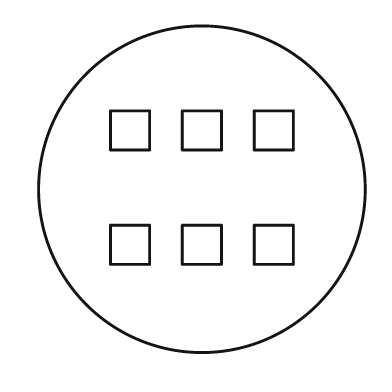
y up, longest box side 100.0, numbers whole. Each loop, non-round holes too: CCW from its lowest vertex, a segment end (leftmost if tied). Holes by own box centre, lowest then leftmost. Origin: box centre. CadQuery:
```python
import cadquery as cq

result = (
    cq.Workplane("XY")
    .moveTo(0.0, 0.0)
    .circle(50.0)
    .moveTo(-28.0, -23.0)
    .lineTo(-16.0, -23.0)
    .lineTo(-16.0, -11.0)
    .lineTo(-28.0, -11.0)
    .close()
    .moveTo(-6.0, -23.0)
    .lineTo(6.0, -23.0)
    .lineTo(6.0, -11.0)
    .lineTo(-6.0, -11.0)
    .close()
    .moveTo(16.0, -23.0)
    .lineTo(28.0, -23.0)
    .lineTo(28.0, -11.0)
    .lineTo(16.0, -11.0)
    .close()
    .moveTo(-28.0, 12.0)
    .lineTo(-16.0, 12.0)
    .lineTo(-16.0, 24.0)
    .lineTo(-28.0, 24.0)
    .close()
    .moveTo(-6.0, 12.0)
    .lineTo(6.0, 12.0)
    .lineTo(6.0, 24.0)
    .lineTo(-6.0, 24.0)
    .close()
    .moveTo(16.0, 12.0)
    .lineTo(28.0, 12.0)
    .lineTo(28.0, 24.0)
    .lineTo(16.0, 24.0)
    .close()
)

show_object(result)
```